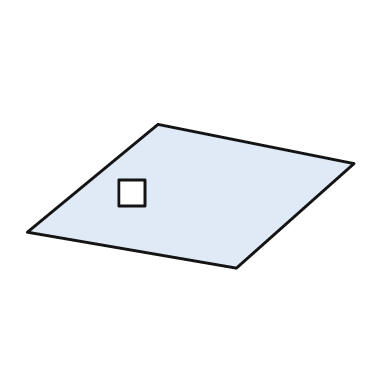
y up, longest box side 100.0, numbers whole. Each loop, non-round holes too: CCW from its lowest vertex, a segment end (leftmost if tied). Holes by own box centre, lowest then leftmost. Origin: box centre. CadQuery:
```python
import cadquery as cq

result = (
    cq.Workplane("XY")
    .moveTo(14.0, -22.0)
    .lineTo(50.0, 10.0)
    .lineTo(-10.0, 22.0)
    .lineTo(-50.0, -11.0)
    .close()
    .moveTo(-22.0, -3.0)
    .lineTo(-14.0, -3.0)
    .lineTo(-14.0, 5.0)
    .lineTo(-22.0, 5.0)
    .close()
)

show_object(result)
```